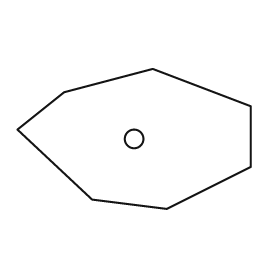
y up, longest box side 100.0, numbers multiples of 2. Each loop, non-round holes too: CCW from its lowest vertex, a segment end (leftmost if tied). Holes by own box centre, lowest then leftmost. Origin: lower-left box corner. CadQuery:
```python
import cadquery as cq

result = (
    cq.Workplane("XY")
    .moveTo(64.0, 0.0)
    .lineTo(100.0, 18.0)
    .lineTo(100.0, 44.0)
    .lineTo(58.0, 60.0)
    .lineTo(20.0, 50.0)
    .lineTo(0.0, 34.0)
    .lineTo(32.0, 4.0)
    .close()
    .moveTo(50.0, 30.0)
    .circle(4.0)
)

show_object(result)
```